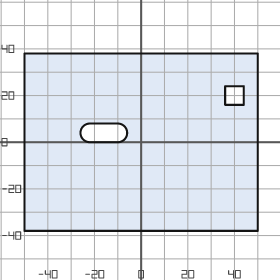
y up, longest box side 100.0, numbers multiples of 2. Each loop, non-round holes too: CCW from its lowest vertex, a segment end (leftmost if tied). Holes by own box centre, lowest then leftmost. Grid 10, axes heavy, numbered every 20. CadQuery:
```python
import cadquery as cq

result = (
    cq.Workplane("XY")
    .moveTo(-50.0, -38.0)
    .lineTo(50.0, -38.0)
    .lineTo(50.0, 38.0)
    .lineTo(-50.0, 38.0)
    .close()
    .moveTo(-22.0, 0.0)
    .lineTo(-10.0, 0.0)
    .threePointArc((-6.0, 4.0), (-10.0, 8.0))
    .lineTo(-22.0, 8.0)
    .threePointArc((-26.0, 4.0), (-22.0, 0.0))
    .close()
    .moveTo(36.0, 16.0)
    .lineTo(44.0, 16.0)
    .lineTo(44.0, 24.0)
    .lineTo(36.0, 24.0)
    .close()
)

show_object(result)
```